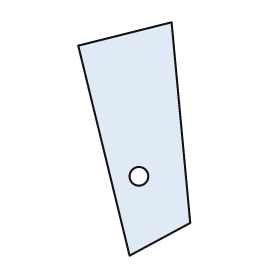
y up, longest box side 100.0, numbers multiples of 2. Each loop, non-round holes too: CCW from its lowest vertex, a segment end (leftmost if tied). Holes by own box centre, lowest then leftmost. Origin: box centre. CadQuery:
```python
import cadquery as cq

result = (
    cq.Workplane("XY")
    .moveTo(-2.0, -50.0)
    .lineTo(24.0, -36.0)
    .lineTo(16.0, 50.0)
    .lineTo(-24.0, 40.0)
    .close()
    .moveTo(2.0, -16.0)
    .circle(4.0)
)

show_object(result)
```